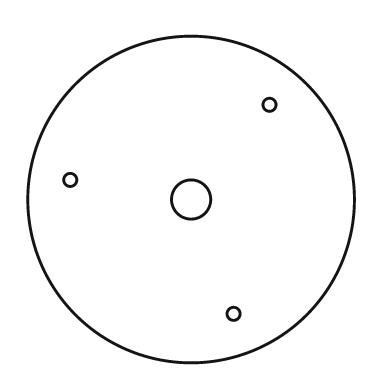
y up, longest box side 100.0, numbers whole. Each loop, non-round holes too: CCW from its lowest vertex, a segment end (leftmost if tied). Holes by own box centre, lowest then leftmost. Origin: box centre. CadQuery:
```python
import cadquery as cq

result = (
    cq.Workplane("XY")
    .moveTo(0.0, 0.0)
    .circle(50.0)
    .moveTo(13.0, -35.0)
    .circle(2.0)
    .moveTo(0.0, 0.0)
    .circle(6.0)
    .moveTo(-37.0, 6.0)
    .circle(2.0)
    .moveTo(24.0, 29.0)
    .circle(2.0)
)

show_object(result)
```